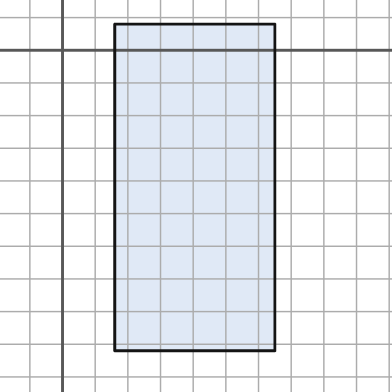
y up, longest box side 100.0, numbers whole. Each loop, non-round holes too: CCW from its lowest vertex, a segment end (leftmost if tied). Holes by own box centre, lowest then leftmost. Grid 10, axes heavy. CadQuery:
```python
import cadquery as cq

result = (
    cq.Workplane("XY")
    .moveTo(16.0, -92.0)
    .lineTo(65.0, -92.0)
    .lineTo(65.0, 8.0)
    .lineTo(16.0, 8.0)
    .close()
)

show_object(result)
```